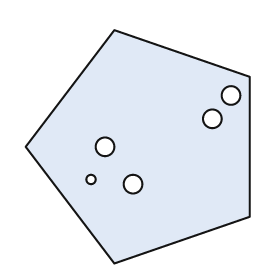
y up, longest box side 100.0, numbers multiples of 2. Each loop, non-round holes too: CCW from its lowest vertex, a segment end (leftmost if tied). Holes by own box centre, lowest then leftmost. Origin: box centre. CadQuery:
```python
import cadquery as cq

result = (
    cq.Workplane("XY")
    .moveTo(-10.0, -50.0)
    .lineTo(48.0, -30.0)
    .lineTo(48.0, 30.0)
    .lineTo(-10.0, 50.0)
    .lineTo(-48.0, 0.0)
    .close()
    .moveTo(-2.0, -16.0)
    .circle(4.0)
    .moveTo(-20.0, -14.0)
    .circle(2.0)
    .moveTo(-14.0, 0.0)
    .circle(4.0)
    .moveTo(32.0, 12.0)
    .circle(4.0)
    .moveTo(40.0, 22.0)
    .circle(4.0)
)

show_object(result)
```